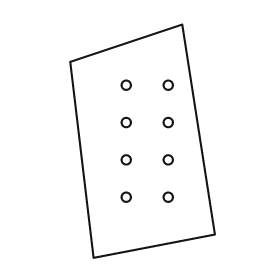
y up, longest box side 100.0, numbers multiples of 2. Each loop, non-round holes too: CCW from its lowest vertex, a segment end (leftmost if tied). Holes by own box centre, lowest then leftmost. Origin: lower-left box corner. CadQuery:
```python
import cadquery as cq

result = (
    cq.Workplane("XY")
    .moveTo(10.0, 0.0)
    .lineTo(62.0, 10.0)
    .lineTo(48.0, 100.0)
    .lineTo(0.0, 84.0)
    .close()
    .moveTo(24.0, 26.0)
    .circle(2.0)
    .moveTo(42.0, 26.0)
    .circle(2.0)
    .moveTo(24.0, 42.0)
    .circle(2.0)
    .moveTo(42.0, 42.0)
    .circle(2.0)
    .moveTo(24.0, 58.0)
    .circle(2.0)
    .moveTo(42.0, 58.0)
    .circle(2.0)
    .moveTo(24.0, 74.0)
    .circle(2.0)
    .moveTo(42.0, 74.0)
    .circle(2.0)
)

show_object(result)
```